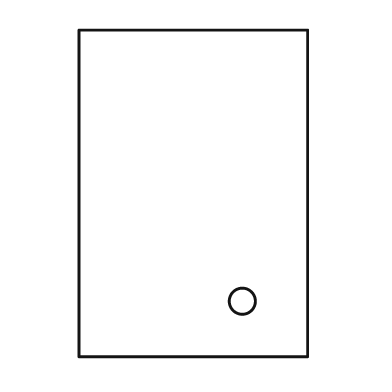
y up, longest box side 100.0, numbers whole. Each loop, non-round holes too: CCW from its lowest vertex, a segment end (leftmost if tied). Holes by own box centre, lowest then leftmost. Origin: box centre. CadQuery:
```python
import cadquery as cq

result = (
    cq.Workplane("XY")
    .moveTo(-35.0, -50.0)
    .lineTo(35.0, -50.0)
    .lineTo(35.0, 50.0)
    .lineTo(-35.0, 50.0)
    .close()
    .moveTo(15.0, -33.0)
    .circle(4.0)
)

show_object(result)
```